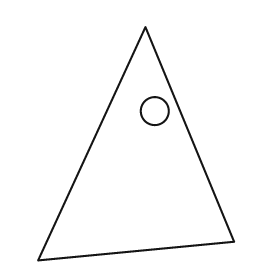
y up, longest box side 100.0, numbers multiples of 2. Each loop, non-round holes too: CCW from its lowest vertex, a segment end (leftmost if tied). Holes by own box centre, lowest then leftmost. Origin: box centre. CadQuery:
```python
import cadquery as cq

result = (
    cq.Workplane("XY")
    .moveTo(-42.0, -50.0)
    .lineTo(42.0, -42.0)
    .lineTo(4.0, 50.0)
    .close()
    .moveTo(8.0, 14.0)
    .circle(6.0)
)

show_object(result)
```